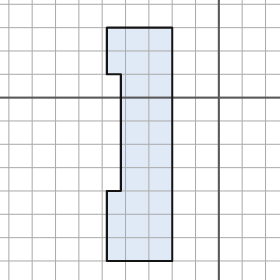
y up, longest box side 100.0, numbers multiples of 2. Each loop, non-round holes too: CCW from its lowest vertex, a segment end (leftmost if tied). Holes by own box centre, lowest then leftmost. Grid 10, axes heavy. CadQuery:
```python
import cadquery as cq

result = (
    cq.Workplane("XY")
    .moveTo(-48.0, -70.0)
    .lineTo(-20.0, -70.0)
    .lineTo(-20.0, 30.0)
    .lineTo(-48.0, 30.0)
    .lineTo(-48.0, 10.0)
    .lineTo(-42.0, 10.0)
    .lineTo(-42.0, -40.0)
    .lineTo(-48.0, -40.0)
    .close()
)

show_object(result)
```